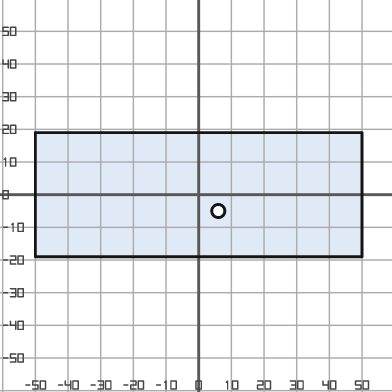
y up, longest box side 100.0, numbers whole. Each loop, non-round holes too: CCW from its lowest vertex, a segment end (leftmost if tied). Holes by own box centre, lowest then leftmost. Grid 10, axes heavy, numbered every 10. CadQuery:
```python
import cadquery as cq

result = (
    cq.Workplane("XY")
    .moveTo(-50.0, -19.0)
    .lineTo(50.0, -19.0)
    .lineTo(50.0, 19.0)
    .lineTo(-50.0, 19.0)
    .close()
    .moveTo(6.0, -5.0)
    .circle(2.0)
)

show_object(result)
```